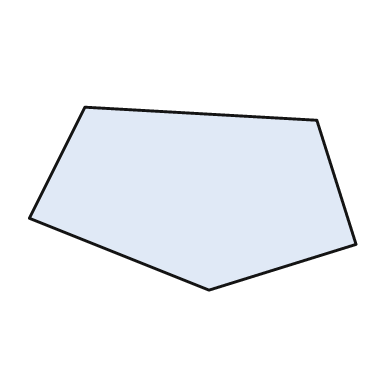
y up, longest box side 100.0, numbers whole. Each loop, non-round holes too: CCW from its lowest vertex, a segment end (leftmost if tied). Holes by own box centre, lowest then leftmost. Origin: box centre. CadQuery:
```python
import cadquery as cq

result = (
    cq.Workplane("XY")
    .moveTo(5.0, -28.0)
    .lineTo(50.0, -14.0)
    .lineTo(38.0, 24.0)
    .lineTo(-33.0, 28.0)
    .lineTo(-50.0, -6.0)
    .close()
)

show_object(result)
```